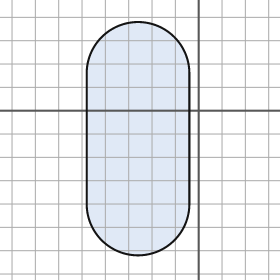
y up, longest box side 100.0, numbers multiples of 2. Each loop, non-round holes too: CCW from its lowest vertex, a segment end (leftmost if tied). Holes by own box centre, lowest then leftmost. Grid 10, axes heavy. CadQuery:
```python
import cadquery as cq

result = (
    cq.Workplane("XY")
    .moveTo(-48.0, -40.0)
    .threePointArc((-26.0, -62.0), (-4.0, -40.0))
    .lineTo(-4.0, 16.0)
    .threePointArc((-26.0, 38.0), (-48.0, 16.0))
    .close()
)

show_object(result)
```